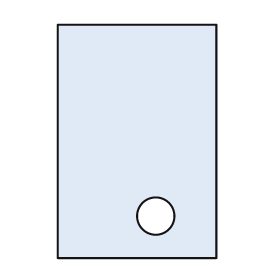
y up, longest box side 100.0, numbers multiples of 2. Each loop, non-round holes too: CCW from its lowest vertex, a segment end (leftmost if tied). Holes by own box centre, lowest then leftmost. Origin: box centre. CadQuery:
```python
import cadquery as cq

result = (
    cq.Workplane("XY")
    .moveTo(-34.0, -50.0)
    .lineTo(34.0, -50.0)
    .lineTo(34.0, 50.0)
    .lineTo(-34.0, 50.0)
    .close()
    .moveTo(8.0, -32.0)
    .circle(8.0)
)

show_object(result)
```